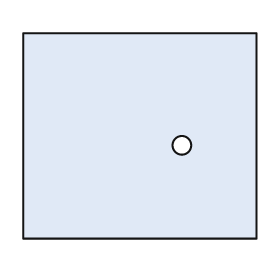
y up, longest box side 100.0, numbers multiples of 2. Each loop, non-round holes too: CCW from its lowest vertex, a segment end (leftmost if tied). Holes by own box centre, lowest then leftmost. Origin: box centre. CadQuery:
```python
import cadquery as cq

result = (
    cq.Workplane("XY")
    .moveTo(-50.0, -44.0)
    .lineTo(50.0, -44.0)
    .lineTo(50.0, 44.0)
    .lineTo(-50.0, 44.0)
    .close()
    .moveTo(18.0, -4.0)
    .circle(4.0)
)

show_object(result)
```